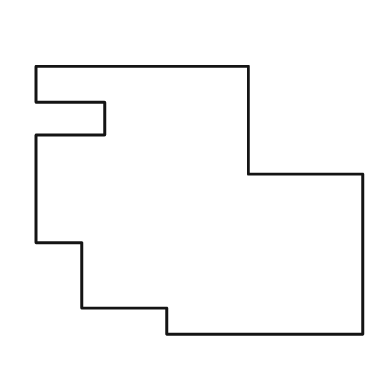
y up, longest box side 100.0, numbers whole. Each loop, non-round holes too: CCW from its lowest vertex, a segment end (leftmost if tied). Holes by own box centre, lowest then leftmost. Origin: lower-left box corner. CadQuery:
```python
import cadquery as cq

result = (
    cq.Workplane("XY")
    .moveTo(40.0, 0.0)
    .lineTo(100.0, 0.0)
    .lineTo(100.0, 49.0)
    .lineTo(65.0, 49.0)
    .lineTo(65.0, 82.0)
    .lineTo(0.0, 82.0)
    .lineTo(0.0, 71.0)
    .lineTo(21.0, 71.0)
    .lineTo(21.0, 61.0)
    .lineTo(0.0, 61.0)
    .lineTo(0.0, 28.0)
    .lineTo(14.0, 28.0)
    .lineTo(14.0, 8.0)
    .lineTo(40.0, 8.0)
    .close()
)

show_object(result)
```